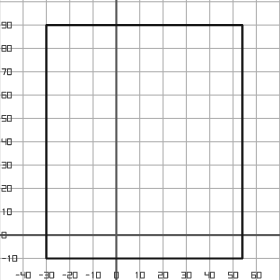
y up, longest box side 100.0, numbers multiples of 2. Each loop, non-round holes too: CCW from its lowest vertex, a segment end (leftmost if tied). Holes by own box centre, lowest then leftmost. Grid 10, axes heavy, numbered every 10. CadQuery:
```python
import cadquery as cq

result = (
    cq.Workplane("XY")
    .moveTo(-30.0, -10.0)
    .lineTo(54.0, -10.0)
    .lineTo(54.0, 90.0)
    .lineTo(-30.0, 90.0)
    .close()
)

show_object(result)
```